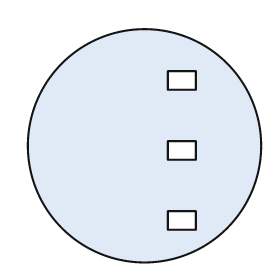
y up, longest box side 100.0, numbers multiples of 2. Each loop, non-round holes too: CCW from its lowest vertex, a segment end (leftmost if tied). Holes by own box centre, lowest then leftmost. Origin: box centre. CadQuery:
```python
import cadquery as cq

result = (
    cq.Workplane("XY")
    .moveTo(0.0, 0.0)
    .circle(50.0)
    .moveTo(10.0, -36.0)
    .lineTo(22.0, -36.0)
    .lineTo(22.0, -28.0)
    .lineTo(10.0, -28.0)
    .close()
    .moveTo(10.0, -6.0)
    .lineTo(22.0, -6.0)
    .lineTo(22.0, 2.0)
    .lineTo(10.0, 2.0)
    .close()
    .moveTo(10.0, 24.0)
    .lineTo(22.0, 24.0)
    .lineTo(22.0, 32.0)
    .lineTo(10.0, 32.0)
    .close()
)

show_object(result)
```